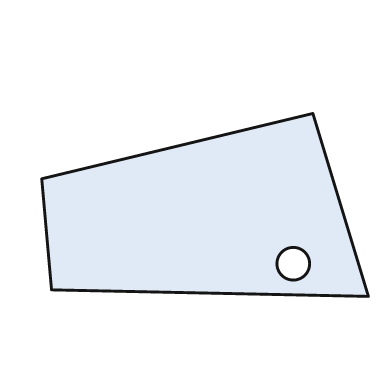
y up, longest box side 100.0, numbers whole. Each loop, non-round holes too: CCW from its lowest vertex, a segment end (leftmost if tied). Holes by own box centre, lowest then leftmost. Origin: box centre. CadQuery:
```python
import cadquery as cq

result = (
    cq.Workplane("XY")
    .moveTo(50.0, -28.0)
    .lineTo(33.0, 28.0)
    .lineTo(-50.0, 8.0)
    .lineTo(-47.0, -26.0)
    .close()
    .moveTo(27.0, -18.0)
    .circle(5.0)
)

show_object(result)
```